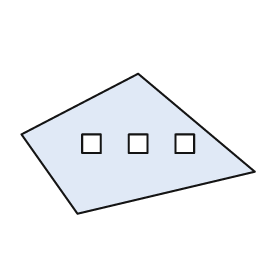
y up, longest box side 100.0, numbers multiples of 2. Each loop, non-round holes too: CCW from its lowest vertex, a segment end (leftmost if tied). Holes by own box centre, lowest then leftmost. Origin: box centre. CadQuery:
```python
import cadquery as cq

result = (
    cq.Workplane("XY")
    .moveTo(-26.0, -30.0)
    .lineTo(50.0, -12.0)
    .lineTo(0.0, 30.0)
    .lineTo(-50.0, 4.0)
    .close()
    .moveTo(-24.0, -4.0)
    .lineTo(-16.0, -4.0)
    .lineTo(-16.0, 4.0)
    .lineTo(-24.0, 4.0)
    .close()
    .moveTo(-4.0, -4.0)
    .lineTo(4.0, -4.0)
    .lineTo(4.0, 4.0)
    .lineTo(-4.0, 4.0)
    .close()
    .moveTo(16.0, -4.0)
    .lineTo(24.0, -4.0)
    .lineTo(24.0, 4.0)
    .lineTo(16.0, 4.0)
    .close()
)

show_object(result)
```